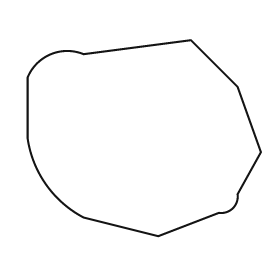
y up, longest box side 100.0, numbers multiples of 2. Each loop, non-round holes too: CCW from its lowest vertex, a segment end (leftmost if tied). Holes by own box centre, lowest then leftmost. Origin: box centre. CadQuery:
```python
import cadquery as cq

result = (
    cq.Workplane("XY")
    .moveTo(6.0, -42.0)
    .lineTo(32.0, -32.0)
    .threePointArc((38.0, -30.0), (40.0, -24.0))
    .lineTo(50.0, -6.0)
    .lineTo(40.0, 22.0)
    .lineTo(20.0, 42.0)
    .lineTo(-26.0, 36.0)
    .threePointArc((-40.0, 36.0), (-50.0, 26.0))
    .lineTo(-50.0, 0.0)
    .threePointArc((-42.0, -20.0), (-26.0, -34.0))
    .close()
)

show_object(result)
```